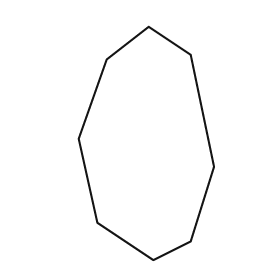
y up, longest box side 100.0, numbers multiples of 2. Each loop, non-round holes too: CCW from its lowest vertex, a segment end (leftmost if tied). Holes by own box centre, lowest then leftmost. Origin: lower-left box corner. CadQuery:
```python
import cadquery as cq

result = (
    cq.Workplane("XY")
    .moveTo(32.0, 0.0)
    .lineTo(48.0, 8.0)
    .lineTo(58.0, 40.0)
    .lineTo(48.0, 88.0)
    .lineTo(30.0, 100.0)
    .lineTo(12.0, 86.0)
    .lineTo(0.0, 52.0)
    .lineTo(8.0, 16.0)
    .close()
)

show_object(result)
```